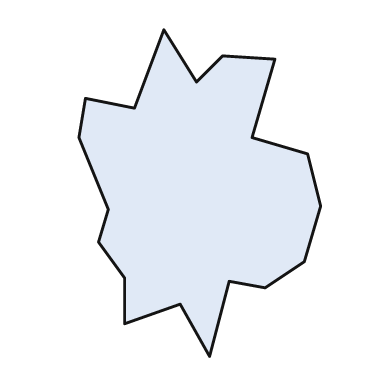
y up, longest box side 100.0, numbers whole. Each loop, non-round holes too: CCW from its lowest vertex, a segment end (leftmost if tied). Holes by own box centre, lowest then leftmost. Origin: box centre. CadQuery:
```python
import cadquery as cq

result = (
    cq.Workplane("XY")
    .moveTo(3.0, -50.0)
    .lineTo(9.0, -27.0)
    .lineTo(20.0, -29.0)
    .lineTo(32.0, -21.0)
    .lineTo(37.0, -4.0)
    .lineTo(33.0, 12.0)
    .lineTo(16.0, 17.0)
    .lineTo(23.0, 41.0)
    .lineTo(7.0, 42.0)
    .lineTo(-1.0, 34.0)
    .lineTo(-11.0, 50.0)
    .lineTo(-20.0, 26.0)
    .lineTo(-35.0, 29.0)
    .lineTo(-37.0, 17.0)
    .lineTo(-28.0, -5.0)
    .lineTo(-31.0, -15.0)
    .lineTo(-23.0, -26.0)
    .lineTo(-23.0, -40.0)
    .lineTo(-6.0, -34.0)
    .close()
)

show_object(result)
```